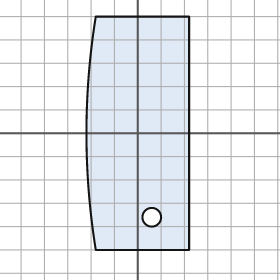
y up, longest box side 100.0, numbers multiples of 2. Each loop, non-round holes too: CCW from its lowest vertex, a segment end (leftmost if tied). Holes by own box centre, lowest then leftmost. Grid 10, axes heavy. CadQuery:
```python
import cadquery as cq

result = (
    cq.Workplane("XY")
    .moveTo(-18.0, -50.0)
    .lineTo(22.0, -50.0)
    .lineTo(22.0, 50.0)
    .lineTo(-18.0, 50.0)
    .threePointArc((-22.0, 0.0), (-18.0, -50.0))
    .close()
    .moveTo(6.0, -36.0)
    .circle(4.0)
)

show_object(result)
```